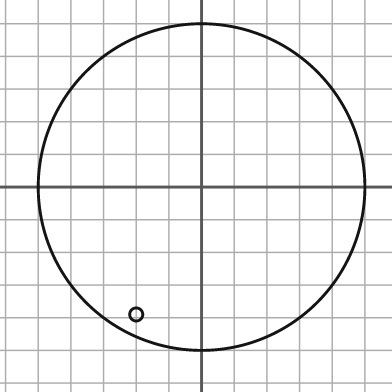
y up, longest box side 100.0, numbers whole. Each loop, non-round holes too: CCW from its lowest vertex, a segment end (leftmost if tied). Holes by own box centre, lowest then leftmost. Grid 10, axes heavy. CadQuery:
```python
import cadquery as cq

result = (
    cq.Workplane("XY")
    .moveTo(0.0, 0.0)
    .circle(50.0)
    .moveTo(-20.0, -39.0)
    .circle(2.0)
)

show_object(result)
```